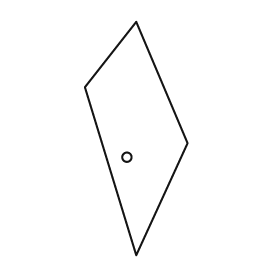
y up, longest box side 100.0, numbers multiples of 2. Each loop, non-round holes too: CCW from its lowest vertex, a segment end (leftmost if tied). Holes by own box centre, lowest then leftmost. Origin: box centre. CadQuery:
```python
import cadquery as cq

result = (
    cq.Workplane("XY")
    .moveTo(0.0, -50.0)
    .lineTo(22.0, -2.0)
    .lineTo(0.0, 50.0)
    .lineTo(-22.0, 22.0)
    .close()
    .moveTo(-4.0, -8.0)
    .circle(2.0)
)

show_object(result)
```